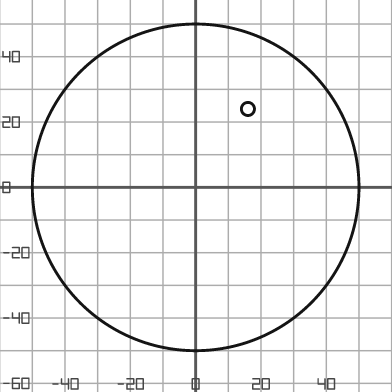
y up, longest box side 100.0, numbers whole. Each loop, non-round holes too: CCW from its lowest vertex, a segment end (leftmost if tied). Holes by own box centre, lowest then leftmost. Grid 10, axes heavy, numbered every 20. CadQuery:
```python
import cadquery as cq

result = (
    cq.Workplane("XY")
    .moveTo(0.0, 0.0)
    .circle(50.0)
    .moveTo(16.0, 24.0)
    .circle(2.0)
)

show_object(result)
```